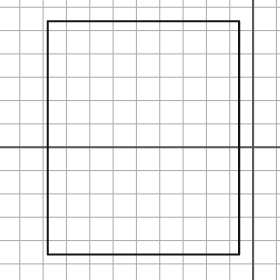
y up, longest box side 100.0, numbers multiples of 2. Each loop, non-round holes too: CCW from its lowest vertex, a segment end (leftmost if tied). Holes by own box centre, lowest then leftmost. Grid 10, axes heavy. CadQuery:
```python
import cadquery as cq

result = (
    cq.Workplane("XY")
    .moveTo(-88.0, -46.0)
    .lineTo(-6.0, -46.0)
    .lineTo(-6.0, 54.0)
    .lineTo(-88.0, 54.0)
    .close()
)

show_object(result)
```